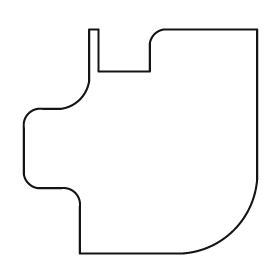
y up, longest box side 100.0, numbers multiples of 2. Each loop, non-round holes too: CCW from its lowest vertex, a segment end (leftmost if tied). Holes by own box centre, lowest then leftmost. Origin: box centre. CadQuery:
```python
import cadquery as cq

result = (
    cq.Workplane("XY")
    .moveTo(-26.0, -48.0)
    .lineTo(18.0, -48.0)
    .threePointArc((40.0, -38.0), (50.0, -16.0))
    .lineTo(50.0, 48.0)
    .lineTo(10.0, 48.0)
    .threePointArc((6.0, 46.0), (4.0, 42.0))
    .lineTo(4.0, 30.0)
    .lineTo(-18.0, 30.0)
    .lineTo(-18.0, 48.0)
    .lineTo(-22.0, 48.0)
    .lineTo(-22.0, 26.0)
    .threePointArc((-26.0, 18.0), (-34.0, 14.0))
    .lineTo(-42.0, 14.0)
    .threePointArc((-48.0, 12.0), (-50.0, 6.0))
    .lineTo(-50.0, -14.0)
    .threePointArc((-48.0, -18.0), (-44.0, -20.0))
    .lineTo(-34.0, -20.0)
    .threePointArc((-28.0, -22.0), (-26.0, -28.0))
    .close()
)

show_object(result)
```